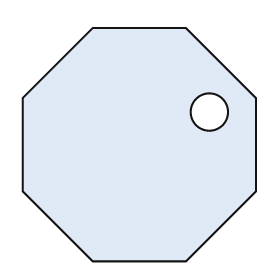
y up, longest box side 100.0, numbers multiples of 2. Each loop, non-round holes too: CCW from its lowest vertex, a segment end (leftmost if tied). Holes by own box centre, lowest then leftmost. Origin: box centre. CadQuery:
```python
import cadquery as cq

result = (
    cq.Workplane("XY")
    .moveTo(-20.0, -50.0)
    .lineTo(20.0, -50.0)
    .lineTo(50.0, -20.0)
    .lineTo(50.0, 20.0)
    .lineTo(20.0, 50.0)
    .lineTo(-20.0, 50.0)
    .lineTo(-50.0, 20.0)
    .lineTo(-50.0, -20.0)
    .close()
    .moveTo(30.0, 14.0)
    .circle(8.0)
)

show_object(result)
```